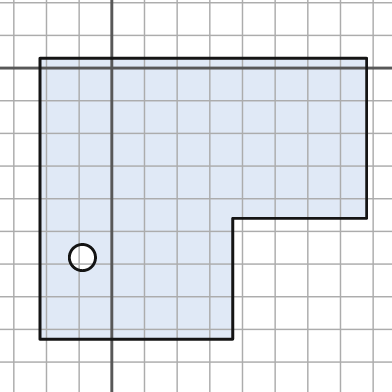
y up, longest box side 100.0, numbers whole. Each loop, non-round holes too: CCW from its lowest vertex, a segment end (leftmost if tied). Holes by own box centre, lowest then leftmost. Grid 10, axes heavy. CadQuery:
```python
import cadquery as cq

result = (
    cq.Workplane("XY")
    .moveTo(-22.0, -83.0)
    .lineTo(37.0, -83.0)
    .lineTo(37.0, -46.0)
    .lineTo(78.0, -46.0)
    .lineTo(78.0, 3.0)
    .lineTo(-22.0, 3.0)
    .close()
    .moveTo(-9.0, -58.0)
    .circle(4.0)
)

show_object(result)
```